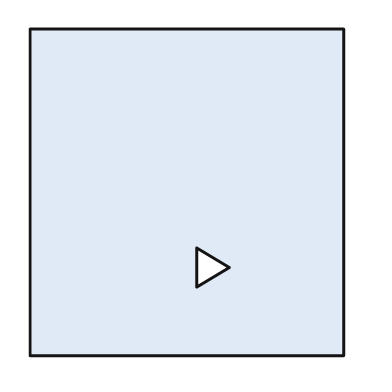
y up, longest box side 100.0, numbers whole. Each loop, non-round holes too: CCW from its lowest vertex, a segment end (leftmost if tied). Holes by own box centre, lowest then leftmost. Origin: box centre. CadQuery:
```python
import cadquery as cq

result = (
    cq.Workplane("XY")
    .moveTo(-48.0, -50.0)
    .lineTo(48.0, -50.0)
    .lineTo(48.0, 50.0)
    .lineTo(-48.0, 50.0)
    .close()
    .moveTo(3.0, -29.0)
    .lineTo(13.0, -23.0)
    .lineTo(3.0, -17.0)
    .close()
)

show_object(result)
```